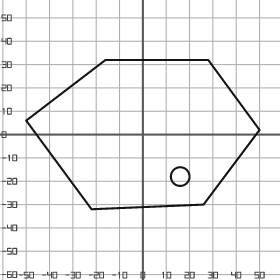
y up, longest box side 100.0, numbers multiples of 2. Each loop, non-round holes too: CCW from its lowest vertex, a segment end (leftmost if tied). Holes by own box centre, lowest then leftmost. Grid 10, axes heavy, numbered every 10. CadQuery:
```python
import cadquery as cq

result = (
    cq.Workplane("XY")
    .moveTo(-22.0, -32.0)
    .lineTo(26.0, -30.0)
    .lineTo(50.0, 2.0)
    .lineTo(28.0, 32.0)
    .lineTo(-16.0, 32.0)
    .lineTo(-50.0, 6.0)
    .close()
    .moveTo(16.0, -18.0)
    .circle(4.0)
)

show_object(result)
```